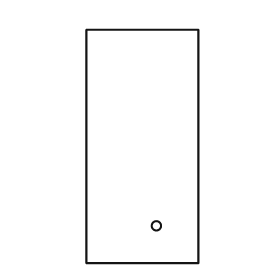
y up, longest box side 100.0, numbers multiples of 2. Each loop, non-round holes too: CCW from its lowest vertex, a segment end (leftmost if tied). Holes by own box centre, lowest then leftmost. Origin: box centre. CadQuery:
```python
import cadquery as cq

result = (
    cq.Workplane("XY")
    .moveTo(-24.0, -50.0)
    .lineTo(24.0, -50.0)
    .lineTo(24.0, 50.0)
    .lineTo(-24.0, 50.0)
    .close()
    .moveTo(6.0, -34.0)
    .circle(2.0)
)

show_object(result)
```